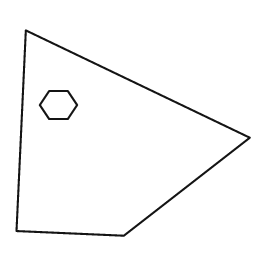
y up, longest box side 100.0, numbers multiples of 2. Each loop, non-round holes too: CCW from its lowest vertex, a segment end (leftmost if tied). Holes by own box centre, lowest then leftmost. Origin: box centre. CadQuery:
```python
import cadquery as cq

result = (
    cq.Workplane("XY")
    .moveTo(-4.0, -44.0)
    .lineTo(50.0, -2.0)
    .lineTo(-46.0, 44.0)
    .lineTo(-50.0, -42.0)
    .close()
    .moveTo(-36.0, 6.0)
    .lineTo(-28.0, 6.0)
    .lineTo(-24.0, 12.0)
    .lineTo(-28.0, 18.0)
    .lineTo(-36.0, 18.0)
    .lineTo(-40.0, 12.0)
    .close()
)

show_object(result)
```